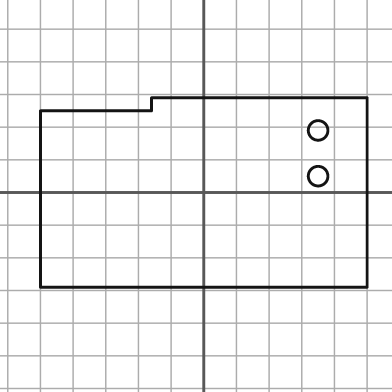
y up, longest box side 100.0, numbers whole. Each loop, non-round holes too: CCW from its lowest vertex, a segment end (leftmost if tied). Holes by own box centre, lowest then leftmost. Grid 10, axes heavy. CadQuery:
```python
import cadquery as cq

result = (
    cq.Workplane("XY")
    .moveTo(-50.0, -29.0)
    .lineTo(50.0, -29.0)
    .lineTo(50.0, 29.0)
    .lineTo(-16.0, 29.0)
    .lineTo(-16.0, 25.0)
    .lineTo(-50.0, 25.0)
    .close()
    .moveTo(35.0, 5.0)
    .circle(3.0)
    .moveTo(35.0, 19.0)
    .circle(3.0)
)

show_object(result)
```